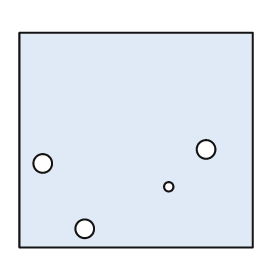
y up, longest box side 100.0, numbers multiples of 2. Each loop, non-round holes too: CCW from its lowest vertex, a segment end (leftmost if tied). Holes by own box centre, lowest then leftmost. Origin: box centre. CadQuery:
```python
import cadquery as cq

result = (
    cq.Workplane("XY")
    .moveTo(-50.0, -46.0)
    .lineTo(50.0, -46.0)
    .lineTo(50.0, 46.0)
    .lineTo(-50.0, 46.0)
    .close()
    .moveTo(-22.0, -38.0)
    .circle(4.0)
    .moveTo(14.0, -20.0)
    .circle(2.0)
    .moveTo(-40.0, -10.0)
    .circle(4.0)
    .moveTo(30.0, -4.0)
    .circle(4.0)
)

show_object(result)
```